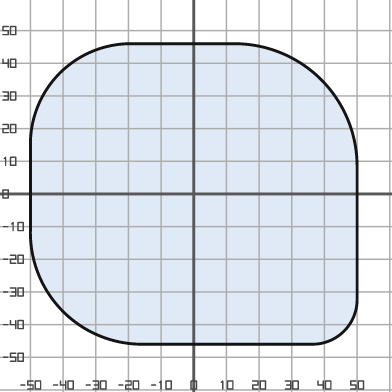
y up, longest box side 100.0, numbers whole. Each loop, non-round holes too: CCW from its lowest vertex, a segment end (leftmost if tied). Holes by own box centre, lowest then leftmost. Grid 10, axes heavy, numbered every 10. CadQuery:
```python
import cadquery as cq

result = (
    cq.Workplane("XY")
    .moveTo(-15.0, -46.0)
    .lineTo(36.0, -46.0)
    .threePointArc((46.0, -42.0), (50.0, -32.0))
    .lineTo(50.0, 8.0)
    .threePointArc((39.0, 35.0), (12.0, 46.0))
    .lineTo(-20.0, 46.0)
    .threePointArc((-41.0, 37.0), (-50.0, 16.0))
    .lineTo(-50.0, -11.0)
    .threePointArc((-40.0, -36.0), (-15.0, -46.0))
    .close()
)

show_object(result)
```